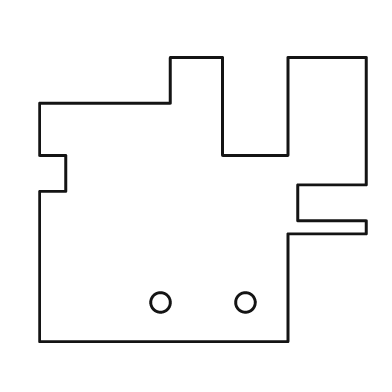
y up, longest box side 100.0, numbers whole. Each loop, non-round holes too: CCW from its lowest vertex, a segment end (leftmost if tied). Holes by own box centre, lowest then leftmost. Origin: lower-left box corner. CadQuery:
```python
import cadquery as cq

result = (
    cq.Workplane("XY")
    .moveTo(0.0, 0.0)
    .lineTo(76.0, 0.0)
    .lineTo(76.0, 33.0)
    .lineTo(100.0, 33.0)
    .lineTo(100.0, 37.0)
    .lineTo(79.0, 37.0)
    .lineTo(79.0, 48.0)
    .lineTo(100.0, 48.0)
    .lineTo(100.0, 87.0)
    .lineTo(76.0, 87.0)
    .lineTo(76.0, 57.0)
    .lineTo(56.0, 57.0)
    .lineTo(56.0, 87.0)
    .lineTo(40.0, 87.0)
    .lineTo(40.0, 73.0)
    .lineTo(0.0, 73.0)
    .lineTo(0.0, 57.0)
    .lineTo(8.0, 57.0)
    .lineTo(8.0, 46.0)
    .lineTo(0.0, 46.0)
    .close()
    .moveTo(37.0, 12.0)
    .circle(3.0)
    .moveTo(63.0, 12.0)
    .circle(3.0)
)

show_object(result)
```